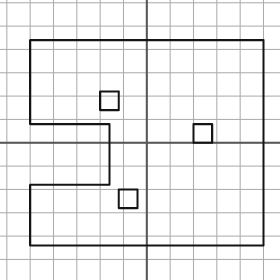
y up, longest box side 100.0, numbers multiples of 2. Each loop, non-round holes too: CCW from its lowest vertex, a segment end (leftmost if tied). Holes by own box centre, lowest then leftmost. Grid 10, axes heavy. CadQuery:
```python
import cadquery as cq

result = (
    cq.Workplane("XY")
    .moveTo(-50.0, -44.0)
    .lineTo(50.0, -44.0)
    .lineTo(50.0, 44.0)
    .lineTo(-50.0, 44.0)
    .lineTo(-50.0, 8.0)
    .lineTo(-16.0, 8.0)
    .lineTo(-16.0, -18.0)
    .lineTo(-50.0, -18.0)
    .close()
    .moveTo(-12.0, -28.0)
    .lineTo(-4.0, -28.0)
    .lineTo(-4.0, -20.0)
    .lineTo(-12.0, -20.0)
    .close()
    .moveTo(20.0, 0.0)
    .lineTo(28.0, 0.0)
    .lineTo(28.0, 8.0)
    .lineTo(20.0, 8.0)
    .close()
    .moveTo(-20.0, 14.0)
    .lineTo(-12.0, 14.0)
    .lineTo(-12.0, 22.0)
    .lineTo(-20.0, 22.0)
    .close()
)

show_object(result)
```